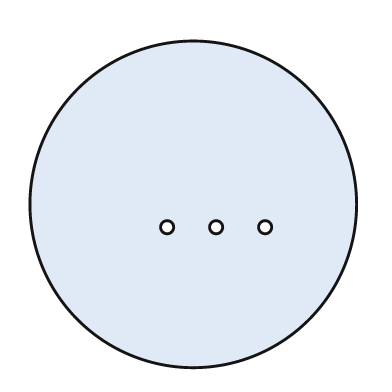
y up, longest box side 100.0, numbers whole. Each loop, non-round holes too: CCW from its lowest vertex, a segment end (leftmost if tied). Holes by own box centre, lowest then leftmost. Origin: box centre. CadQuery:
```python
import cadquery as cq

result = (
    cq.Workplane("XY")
    .moveTo(0.0, 0.0)
    .circle(50.0)
    .moveTo(-8.0, -7.0)
    .circle(2.0)
    .moveTo(7.0, -7.0)
    .circle(2.0)
    .moveTo(22.0, -7.0)
    .circle(2.0)
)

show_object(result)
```